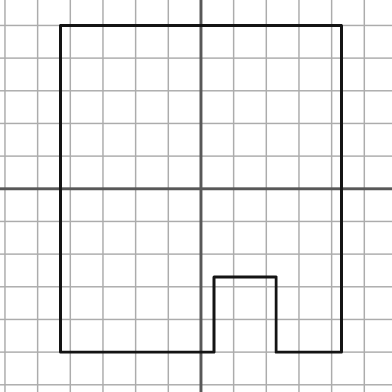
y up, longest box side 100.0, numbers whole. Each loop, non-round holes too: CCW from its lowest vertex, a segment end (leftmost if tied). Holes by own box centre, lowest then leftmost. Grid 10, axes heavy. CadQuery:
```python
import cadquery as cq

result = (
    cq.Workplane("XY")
    .moveTo(-43.0, -50.0)
    .lineTo(4.0, -50.0)
    .lineTo(4.0, -27.0)
    .lineTo(23.0, -27.0)
    .lineTo(23.0, -50.0)
    .lineTo(43.0, -50.0)
    .lineTo(43.0, 50.0)
    .lineTo(-43.0, 50.0)
    .close()
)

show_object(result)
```